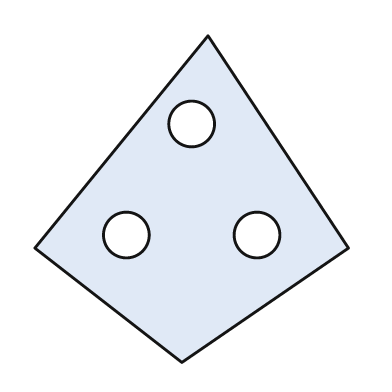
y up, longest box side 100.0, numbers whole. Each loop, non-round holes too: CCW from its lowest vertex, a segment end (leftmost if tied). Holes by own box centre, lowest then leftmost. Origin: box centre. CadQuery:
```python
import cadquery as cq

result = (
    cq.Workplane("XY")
    .moveTo(-3.0, -50.0)
    .lineTo(48.0, -15.0)
    .lineTo(5.0, 50.0)
    .lineTo(-48.0, -15.0)
    .close()
    .moveTo(-20.0, -11.0)
    .circle(7.0)
    .moveTo(20.0, -11.0)
    .circle(7.0)
    .moveTo(0.0, 23.0)
    .circle(7.0)
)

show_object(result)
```